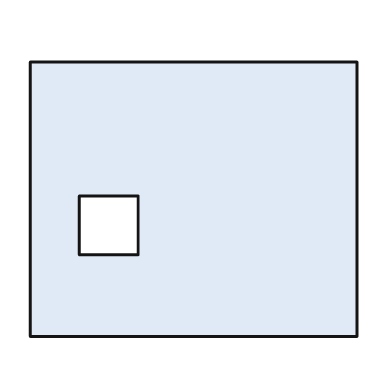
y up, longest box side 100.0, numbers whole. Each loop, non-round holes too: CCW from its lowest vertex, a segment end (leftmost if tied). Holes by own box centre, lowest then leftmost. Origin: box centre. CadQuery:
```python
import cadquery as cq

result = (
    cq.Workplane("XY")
    .moveTo(-50.0, -42.0)
    .lineTo(50.0, -42.0)
    .lineTo(50.0, 42.0)
    .lineTo(-50.0, 42.0)
    .close()
    .moveTo(-35.0, -17.0)
    .lineTo(-17.0, -17.0)
    .lineTo(-17.0, 1.0)
    .lineTo(-35.0, 1.0)
    .close()
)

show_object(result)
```